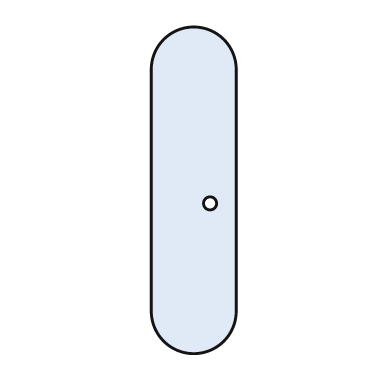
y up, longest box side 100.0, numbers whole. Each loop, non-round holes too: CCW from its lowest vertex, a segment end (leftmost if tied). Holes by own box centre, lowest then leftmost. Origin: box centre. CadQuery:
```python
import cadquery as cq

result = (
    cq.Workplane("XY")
    .moveTo(-13.0, -37.0)
    .threePointArc((0.0, -50.0), (13.0, -37.0))
    .lineTo(13.0, 37.0)
    .threePointArc((0.0, 50.0), (-13.0, 37.0))
    .close()
    .moveTo(5.0, -4.0)
    .circle(2.0)
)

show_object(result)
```